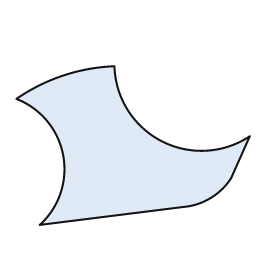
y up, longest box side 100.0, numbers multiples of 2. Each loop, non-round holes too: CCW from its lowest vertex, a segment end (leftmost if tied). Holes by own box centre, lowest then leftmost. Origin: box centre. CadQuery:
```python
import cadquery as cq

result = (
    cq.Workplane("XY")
    .moveTo(-40.0, -34.0)
    .lineTo(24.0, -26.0)
    .threePointArc((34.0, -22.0), (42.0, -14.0))
    .lineTo(50.0, 4.0)
    .threePointArc((12.0, 2.0), (-8.0, 34.0))
    .threePointArc((-30.0, 30.0), (-50.0, 20.0))
    .threePointArc((-30.0, -4.0), (-40.0, -34.0))
    .close()
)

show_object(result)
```